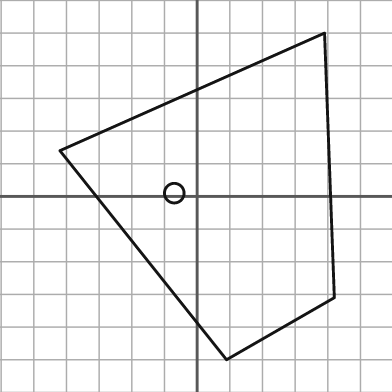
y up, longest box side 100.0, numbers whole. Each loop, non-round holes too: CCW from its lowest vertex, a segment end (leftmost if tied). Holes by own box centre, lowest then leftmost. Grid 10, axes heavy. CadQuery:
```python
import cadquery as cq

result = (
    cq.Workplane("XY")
    .moveTo(9.0, -50.0)
    .lineTo(42.0, -31.0)
    .lineTo(39.0, 50.0)
    .lineTo(-42.0, 14.0)
    .close()
    .moveTo(-7.0, 1.0)
    .circle(3.0)
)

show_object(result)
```